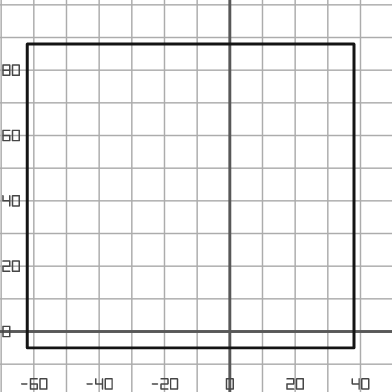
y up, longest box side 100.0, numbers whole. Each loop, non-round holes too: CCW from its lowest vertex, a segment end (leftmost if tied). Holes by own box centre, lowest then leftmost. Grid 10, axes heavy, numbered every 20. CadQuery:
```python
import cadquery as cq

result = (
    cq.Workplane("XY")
    .moveTo(-62.0, -5.0)
    .lineTo(38.0, -5.0)
    .lineTo(38.0, 88.0)
    .lineTo(-62.0, 88.0)
    .close()
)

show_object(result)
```